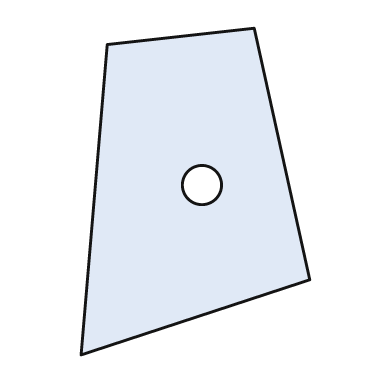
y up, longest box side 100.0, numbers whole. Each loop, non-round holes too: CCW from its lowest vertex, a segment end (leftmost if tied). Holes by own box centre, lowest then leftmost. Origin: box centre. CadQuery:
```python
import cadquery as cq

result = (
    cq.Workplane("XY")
    .moveTo(-35.0, -50.0)
    .lineTo(35.0, -27.0)
    .lineTo(18.0, 50.0)
    .lineTo(-27.0, 45.0)
    .close()
    .moveTo(2.0, 2.0)
    .circle(6.0)
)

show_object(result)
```